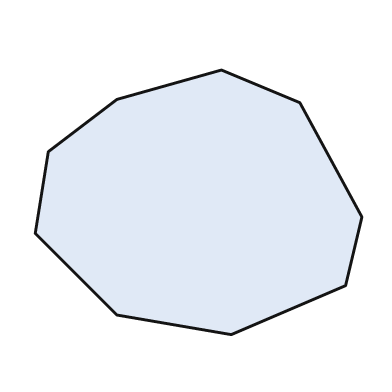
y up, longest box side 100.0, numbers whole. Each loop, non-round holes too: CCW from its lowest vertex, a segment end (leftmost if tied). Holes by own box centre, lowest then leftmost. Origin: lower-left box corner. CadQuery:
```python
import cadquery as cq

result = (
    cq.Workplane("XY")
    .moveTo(60.0, 0.0)
    .lineTo(95.0, 15.0)
    .lineTo(100.0, 36.0)
    .lineTo(81.0, 71.0)
    .lineTo(57.0, 81.0)
    .lineTo(25.0, 72.0)
    .lineTo(4.0, 56.0)
    .lineTo(0.0, 31.0)
    .lineTo(25.0, 6.0)
    .close()
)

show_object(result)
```